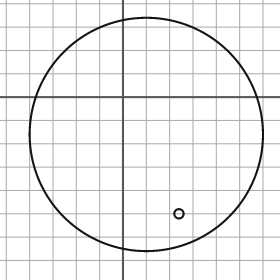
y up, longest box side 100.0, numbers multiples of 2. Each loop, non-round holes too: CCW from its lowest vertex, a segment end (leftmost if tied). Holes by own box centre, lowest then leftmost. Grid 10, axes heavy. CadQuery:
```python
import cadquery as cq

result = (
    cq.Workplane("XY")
    .moveTo(10.0, -16.0)
    .circle(50.0)
    .moveTo(24.0, -50.0)
    .circle(2.0)
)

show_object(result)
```